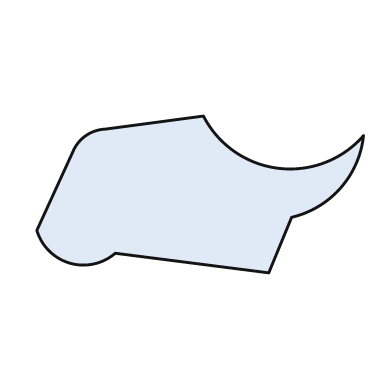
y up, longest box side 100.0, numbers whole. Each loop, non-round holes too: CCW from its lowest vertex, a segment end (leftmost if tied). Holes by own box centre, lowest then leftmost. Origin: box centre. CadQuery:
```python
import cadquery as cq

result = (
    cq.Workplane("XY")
    .moveTo(21.0, -24.0)
    .lineTo(28.0, -7.0)
    .threePointArc((43.0, 2.0), (50.0, 18.0))
    .threePointArc((24.0, 8.0), (1.0, 24.0))
    .lineTo(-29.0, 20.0)
    .threePointArc((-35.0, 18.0), (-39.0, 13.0))
    .lineTo(-50.0, -11.0)
    .threePointArc((-40.0, -21.0), (-26.0, -18.0))
    .close()
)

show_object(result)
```